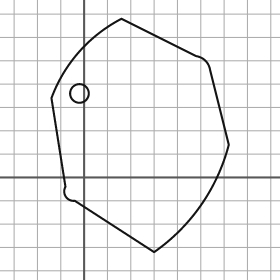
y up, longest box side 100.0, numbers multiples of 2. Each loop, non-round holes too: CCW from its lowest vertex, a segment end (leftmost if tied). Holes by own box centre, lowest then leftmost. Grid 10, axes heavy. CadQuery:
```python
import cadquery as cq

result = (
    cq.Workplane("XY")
    .moveTo(30.0, -32.0)
    .threePointArc((50.0, -12.0), (62.0, 14.0))
    .lineTo(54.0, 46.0)
    .threePointArc((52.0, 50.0), (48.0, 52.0))
    .lineTo(16.0, 68.0)
    .threePointArc((-2.0, 54.0), (-14.0, 34.0))
    .lineTo(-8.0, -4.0)
    .threePointArc((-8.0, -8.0), (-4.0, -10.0))
    .close()
    .moveTo(-2.0, 36.0)
    .circle(4.0)
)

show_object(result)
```